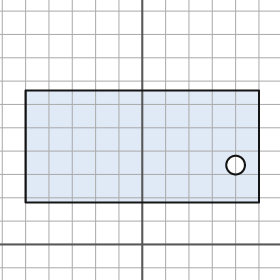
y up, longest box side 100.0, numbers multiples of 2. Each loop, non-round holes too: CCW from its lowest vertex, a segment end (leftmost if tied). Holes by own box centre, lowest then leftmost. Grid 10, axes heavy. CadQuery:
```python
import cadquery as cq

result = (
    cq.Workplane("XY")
    .moveTo(-50.0, 18.0)
    .lineTo(50.0, 18.0)
    .lineTo(50.0, 66.0)
    .lineTo(-50.0, 66.0)
    .close()
    .moveTo(40.0, 34.0)
    .circle(4.0)
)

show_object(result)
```